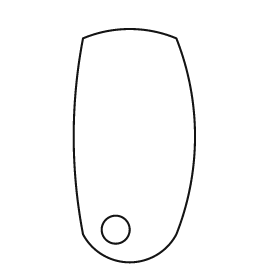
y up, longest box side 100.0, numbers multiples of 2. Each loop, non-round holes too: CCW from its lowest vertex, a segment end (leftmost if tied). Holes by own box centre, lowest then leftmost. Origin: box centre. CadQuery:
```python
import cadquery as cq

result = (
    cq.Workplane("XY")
    .moveTo(-22.0, -38.0)
    .threePointArc((-2.0, -50.0), (18.0, -38.0))
    .threePointArc((26.0, 4.0), (18.0, 46.0))
    .threePointArc((-2.0, 50.0), (-22.0, 46.0))
    .threePointArc((-26.0, 4.0), (-22.0, -38.0))
    .close()
    .moveTo(-8.0, -36.0)
    .circle(6.0)
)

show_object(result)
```